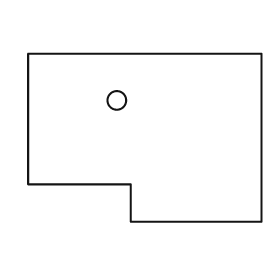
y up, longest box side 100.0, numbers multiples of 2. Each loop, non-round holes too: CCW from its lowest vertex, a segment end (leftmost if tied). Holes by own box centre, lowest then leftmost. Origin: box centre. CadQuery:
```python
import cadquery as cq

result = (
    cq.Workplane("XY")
    .moveTo(-6.0, -36.0)
    .lineTo(50.0, -36.0)
    .lineTo(50.0, 36.0)
    .lineTo(-50.0, 36.0)
    .lineTo(-50.0, -20.0)
    .lineTo(-6.0, -20.0)
    .close()
    .moveTo(-12.0, 16.0)
    .circle(4.0)
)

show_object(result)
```